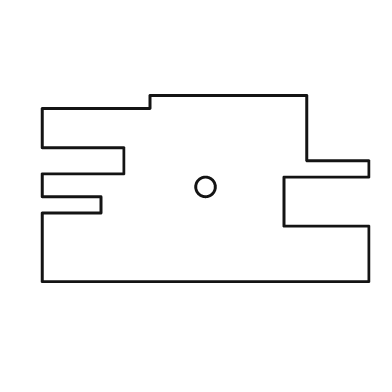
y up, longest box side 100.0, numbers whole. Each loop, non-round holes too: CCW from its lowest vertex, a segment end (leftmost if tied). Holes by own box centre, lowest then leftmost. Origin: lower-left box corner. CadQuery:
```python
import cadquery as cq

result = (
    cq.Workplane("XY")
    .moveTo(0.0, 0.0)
    .lineTo(100.0, 0.0)
    .lineTo(100.0, 17.0)
    .lineTo(74.0, 17.0)
    .lineTo(74.0, 32.0)
    .lineTo(100.0, 32.0)
    .lineTo(100.0, 37.0)
    .lineTo(81.0, 37.0)
    .lineTo(81.0, 57.0)
    .lineTo(33.0, 57.0)
    .lineTo(33.0, 53.0)
    .lineTo(0.0, 53.0)
    .lineTo(0.0, 41.0)
    .lineTo(25.0, 41.0)
    .lineTo(25.0, 33.0)
    .lineTo(0.0, 33.0)
    .lineTo(0.0, 26.0)
    .lineTo(18.0, 26.0)
    .lineTo(18.0, 21.0)
    .lineTo(0.0, 21.0)
    .close()
    .moveTo(50.0, 29.0)
    .circle(3.0)
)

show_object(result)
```